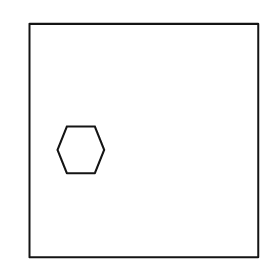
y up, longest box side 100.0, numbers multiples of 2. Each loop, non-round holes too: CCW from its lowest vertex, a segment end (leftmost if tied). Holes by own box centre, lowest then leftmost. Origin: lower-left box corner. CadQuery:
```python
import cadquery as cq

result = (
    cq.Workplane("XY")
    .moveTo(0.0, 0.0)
    .lineTo(98.0, 0.0)
    .lineTo(98.0, 100.0)
    .lineTo(0.0, 100.0)
    .close()
    .moveTo(16.0, 36.0)
    .lineTo(28.0, 36.0)
    .lineTo(32.0, 46.0)
    .lineTo(28.0, 56.0)
    .lineTo(16.0, 56.0)
    .lineTo(12.0, 46.0)
    .close()
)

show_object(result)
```